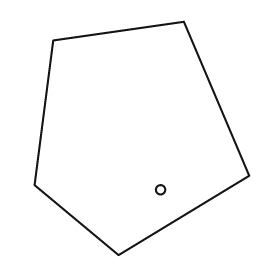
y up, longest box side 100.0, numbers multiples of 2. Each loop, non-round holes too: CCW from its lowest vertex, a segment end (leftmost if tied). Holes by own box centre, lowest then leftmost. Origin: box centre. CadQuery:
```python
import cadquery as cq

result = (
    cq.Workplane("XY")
    .moveTo(-10.0, -50.0)
    .lineTo(46.0, -16.0)
    .lineTo(18.0, 50.0)
    .lineTo(-38.0, 42.0)
    .lineTo(-46.0, -20.0)
    .close()
    .moveTo(8.0, -22.0)
    .circle(2.0)
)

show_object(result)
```